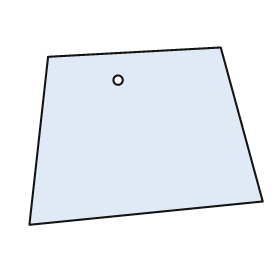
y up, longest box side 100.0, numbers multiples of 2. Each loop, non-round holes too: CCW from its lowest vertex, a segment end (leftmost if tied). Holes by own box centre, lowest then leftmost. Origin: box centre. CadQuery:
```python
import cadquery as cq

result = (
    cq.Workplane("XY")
    .moveTo(-50.0, -38.0)
    .lineTo(50.0, -28.0)
    .lineTo(32.0, 38.0)
    .lineTo(-42.0, 34.0)
    .close()
    .moveTo(-12.0, 24.0)
    .circle(2.0)
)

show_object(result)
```